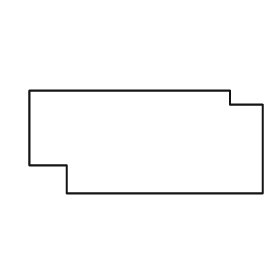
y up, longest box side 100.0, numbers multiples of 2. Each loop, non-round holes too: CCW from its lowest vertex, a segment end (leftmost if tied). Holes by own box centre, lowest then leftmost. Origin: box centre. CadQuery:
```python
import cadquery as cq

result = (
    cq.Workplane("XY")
    .moveTo(-34.0, -22.0)
    .lineTo(50.0, -22.0)
    .lineTo(50.0, 16.0)
    .lineTo(36.0, 16.0)
    .lineTo(36.0, 22.0)
    .lineTo(-50.0, 22.0)
    .lineTo(-50.0, -10.0)
    .lineTo(-34.0, -10.0)
    .close()
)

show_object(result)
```